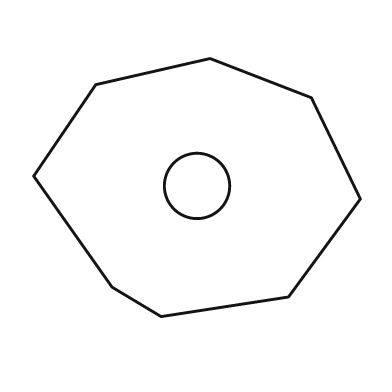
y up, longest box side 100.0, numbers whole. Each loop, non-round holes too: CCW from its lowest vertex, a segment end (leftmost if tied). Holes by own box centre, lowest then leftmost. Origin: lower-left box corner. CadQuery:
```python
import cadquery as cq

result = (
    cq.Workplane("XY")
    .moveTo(39.0, 0.0)
    .lineTo(78.0, 6.0)
    .lineTo(100.0, 36.0)
    .lineTo(85.0, 67.0)
    .lineTo(54.0, 79.0)
    .lineTo(19.0, 71.0)
    .lineTo(0.0, 43.0)
    .lineTo(24.0, 9.0)
    .close()
    .moveTo(50.0, 40.0)
    .circle(10.0)
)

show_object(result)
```